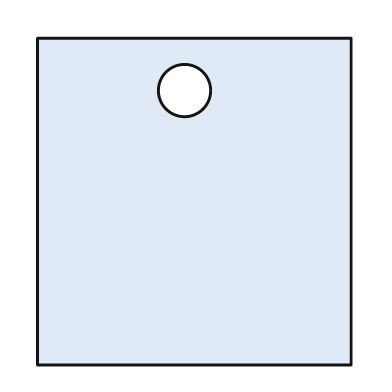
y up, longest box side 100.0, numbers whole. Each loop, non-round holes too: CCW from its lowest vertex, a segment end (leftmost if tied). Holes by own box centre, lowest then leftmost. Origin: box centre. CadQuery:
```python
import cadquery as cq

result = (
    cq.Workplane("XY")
    .moveTo(-48.0, -50.0)
    .lineTo(48.0, -50.0)
    .lineTo(48.0, 50.0)
    .lineTo(-48.0, 50.0)
    .close()
    .moveTo(-3.0, 34.0)
    .circle(8.0)
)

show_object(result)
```